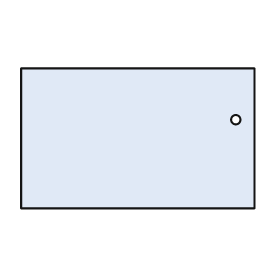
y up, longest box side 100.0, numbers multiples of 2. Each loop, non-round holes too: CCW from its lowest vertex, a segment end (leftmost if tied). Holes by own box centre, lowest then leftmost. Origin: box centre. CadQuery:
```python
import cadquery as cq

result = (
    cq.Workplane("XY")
    .moveTo(-50.0, -30.0)
    .lineTo(50.0, -30.0)
    .lineTo(50.0, 30.0)
    .lineTo(-50.0, 30.0)
    .close()
    .moveTo(42.0, 8.0)
    .circle(2.0)
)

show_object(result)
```